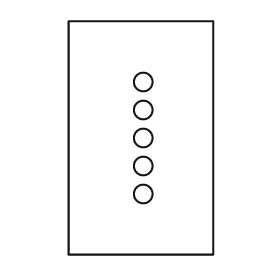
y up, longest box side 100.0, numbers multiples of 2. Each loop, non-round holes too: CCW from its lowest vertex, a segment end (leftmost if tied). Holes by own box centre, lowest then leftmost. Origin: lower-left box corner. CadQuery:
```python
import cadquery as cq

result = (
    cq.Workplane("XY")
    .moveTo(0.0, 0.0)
    .lineTo(62.0, 0.0)
    .lineTo(62.0, 100.0)
    .lineTo(0.0, 100.0)
    .close()
    .moveTo(32.0, 26.0)
    .circle(4.0)
    .moveTo(32.0, 38.0)
    .circle(4.0)
    .moveTo(32.0, 50.0)
    .circle(4.0)
    .moveTo(32.0, 62.0)
    .circle(4.0)
    .moveTo(32.0, 74.0)
    .circle(4.0)
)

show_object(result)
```